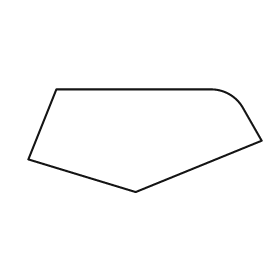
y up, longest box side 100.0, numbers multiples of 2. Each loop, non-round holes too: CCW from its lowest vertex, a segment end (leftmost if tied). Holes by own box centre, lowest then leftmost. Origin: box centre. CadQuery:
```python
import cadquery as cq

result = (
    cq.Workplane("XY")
    .moveTo(-4.0, -22.0)
    .lineTo(50.0, 0.0)
    .lineTo(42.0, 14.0)
    .threePointArc((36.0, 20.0), (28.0, 22.0))
    .lineTo(-38.0, 22.0)
    .lineTo(-50.0, -8.0)
    .close()
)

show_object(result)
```